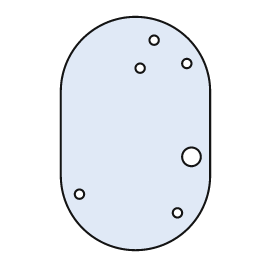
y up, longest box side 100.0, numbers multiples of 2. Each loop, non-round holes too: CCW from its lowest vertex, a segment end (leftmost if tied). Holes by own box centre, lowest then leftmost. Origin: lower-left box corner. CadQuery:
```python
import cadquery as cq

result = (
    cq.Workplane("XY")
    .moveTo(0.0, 32.0)
    .threePointArc((32.0, 0.0), (64.0, 32.0))
    .lineTo(64.0, 68.0)
    .threePointArc((32.0, 100.0), (0.0, 68.0))
    .close()
    .moveTo(50.0, 16.0)
    .circle(2.0)
    .moveTo(8.0, 24.0)
    .circle(2.0)
    .moveTo(56.0, 40.0)
    .circle(4.0)
    .moveTo(34.0, 78.0)
    .circle(2.0)
    .moveTo(54.0, 80.0)
    .circle(2.0)
    .moveTo(40.0, 90.0)
    .circle(2.0)
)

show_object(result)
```